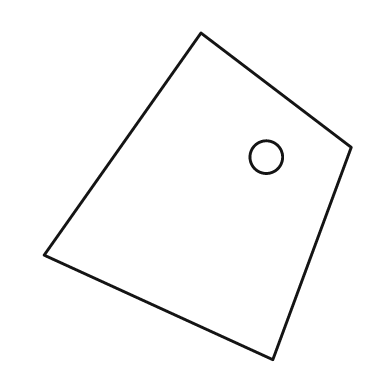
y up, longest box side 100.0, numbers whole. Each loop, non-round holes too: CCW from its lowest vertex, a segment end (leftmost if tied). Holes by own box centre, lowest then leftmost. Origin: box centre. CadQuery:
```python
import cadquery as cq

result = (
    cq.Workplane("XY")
    .moveTo(23.0, -50.0)
    .lineTo(47.0, 15.0)
    .lineTo(1.0, 50.0)
    .lineTo(-47.0, -18.0)
    .close()
    .moveTo(21.0, 12.0)
    .circle(5.0)
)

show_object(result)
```